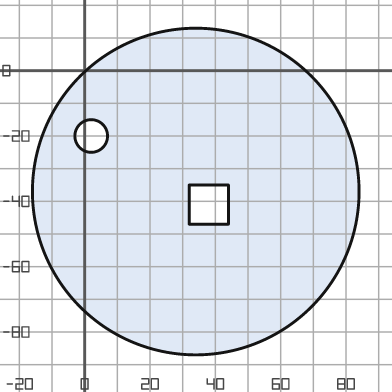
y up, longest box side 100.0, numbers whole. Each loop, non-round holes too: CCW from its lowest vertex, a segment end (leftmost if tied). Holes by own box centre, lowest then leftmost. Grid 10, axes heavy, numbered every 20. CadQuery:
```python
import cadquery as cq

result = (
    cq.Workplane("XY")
    .moveTo(34.0, -37.0)
    .circle(50.0)
    .moveTo(32.0, -47.0)
    .lineTo(44.0, -47.0)
    .lineTo(44.0, -35.0)
    .lineTo(32.0, -35.0)
    .close()
    .moveTo(2.0, -20.0)
    .circle(5.0)
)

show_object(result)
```